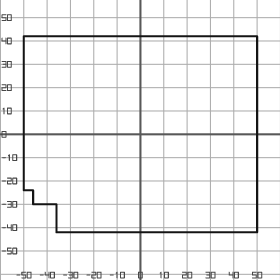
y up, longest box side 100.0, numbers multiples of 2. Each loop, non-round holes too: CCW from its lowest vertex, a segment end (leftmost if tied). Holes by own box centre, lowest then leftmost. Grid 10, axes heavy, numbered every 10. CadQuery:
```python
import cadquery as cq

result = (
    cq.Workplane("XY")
    .moveTo(-36.0, -42.0)
    .lineTo(50.0, -42.0)
    .lineTo(50.0, 42.0)
    .lineTo(-50.0, 42.0)
    .lineTo(-50.0, -24.0)
    .lineTo(-46.0, -24.0)
    .lineTo(-46.0, -30.0)
    .lineTo(-36.0, -30.0)
    .close()
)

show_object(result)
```